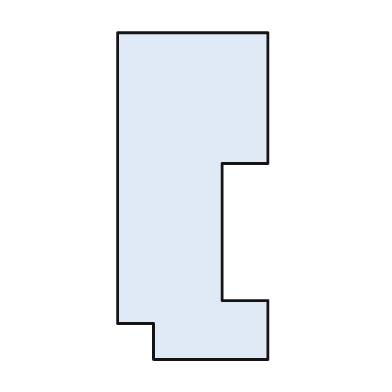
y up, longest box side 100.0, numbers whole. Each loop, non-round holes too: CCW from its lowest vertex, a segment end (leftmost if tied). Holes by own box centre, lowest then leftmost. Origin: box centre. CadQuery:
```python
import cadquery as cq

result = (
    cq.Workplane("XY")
    .moveTo(-12.0, -50.0)
    .lineTo(23.0, -50.0)
    .lineTo(23.0, -32.0)
    .lineTo(9.0, -32.0)
    .lineTo(9.0, 10.0)
    .lineTo(23.0, 10.0)
    .lineTo(23.0, 50.0)
    .lineTo(-23.0, 50.0)
    .lineTo(-23.0, -39.0)
    .lineTo(-12.0, -39.0)
    .close()
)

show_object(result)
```